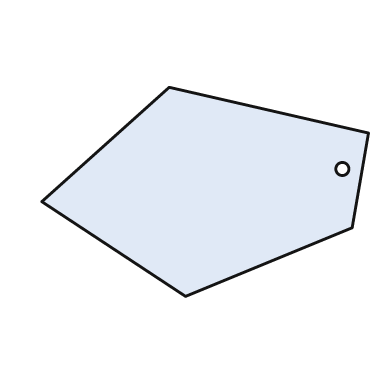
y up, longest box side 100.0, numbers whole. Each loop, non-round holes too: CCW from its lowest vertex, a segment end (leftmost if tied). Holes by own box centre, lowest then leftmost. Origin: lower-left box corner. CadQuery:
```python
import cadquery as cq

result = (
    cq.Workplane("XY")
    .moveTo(44.0, 0.0)
    .lineTo(95.0, 21.0)
    .lineTo(100.0, 50.0)
    .lineTo(39.0, 64.0)
    .lineTo(0.0, 29.0)
    .close()
    .moveTo(92.0, 39.0)
    .circle(2.0)
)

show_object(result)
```